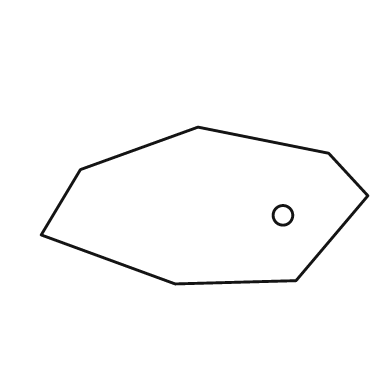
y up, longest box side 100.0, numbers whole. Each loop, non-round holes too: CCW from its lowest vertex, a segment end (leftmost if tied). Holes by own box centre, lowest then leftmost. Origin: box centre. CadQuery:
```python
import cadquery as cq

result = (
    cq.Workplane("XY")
    .moveTo(-9.0, -24.0)
    .lineTo(28.0, -23.0)
    .lineTo(50.0, 3.0)
    .lineTo(38.0, 16.0)
    .lineTo(-2.0, 24.0)
    .lineTo(-38.0, 11.0)
    .lineTo(-50.0, -9.0)
    .close()
    .moveTo(24.0, -3.0)
    .circle(3.0)
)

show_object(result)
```